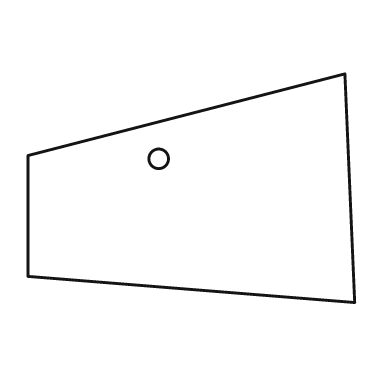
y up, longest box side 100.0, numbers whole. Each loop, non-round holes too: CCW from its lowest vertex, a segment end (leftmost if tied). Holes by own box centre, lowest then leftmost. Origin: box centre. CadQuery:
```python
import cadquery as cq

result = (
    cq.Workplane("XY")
    .moveTo(50.0, -35.0)
    .lineTo(47.0, 35.0)
    .lineTo(-50.0, 10.0)
    .lineTo(-50.0, -27.0)
    .close()
    .moveTo(-10.0, 9.0)
    .circle(3.0)
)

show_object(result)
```